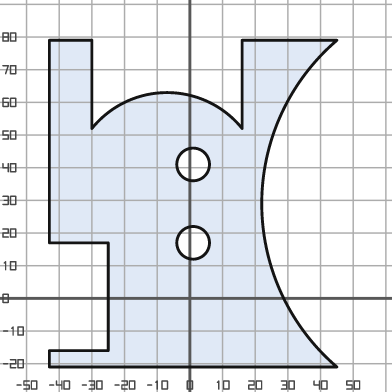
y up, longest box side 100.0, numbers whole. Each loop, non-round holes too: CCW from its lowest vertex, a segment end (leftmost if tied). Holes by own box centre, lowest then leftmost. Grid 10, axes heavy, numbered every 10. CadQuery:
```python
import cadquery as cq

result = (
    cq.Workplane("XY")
    .moveTo(-43.0, -21.0)
    .lineTo(45.0, -21.0)
    .threePointArc((22.0, 29.0), (45.0, 79.0))
    .lineTo(16.0, 79.0)
    .lineTo(16.0, 52.0)
    .threePointArc((-7.0, 63.0), (-30.0, 52.0))
    .lineTo(-30.0, 79.0)
    .lineTo(-43.0, 79.0)
    .lineTo(-43.0, 17.0)
    .lineTo(-25.0, 17.0)
    .lineTo(-25.0, -16.0)
    .lineTo(-43.0, -16.0)
    .close()
    .moveTo(1.0, 17.0)
    .circle(5.0)
    .moveTo(1.0, 41.0)
    .circle(5.0)
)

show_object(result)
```